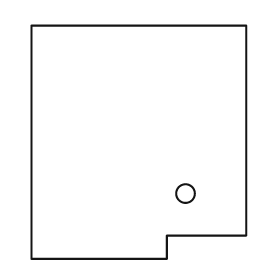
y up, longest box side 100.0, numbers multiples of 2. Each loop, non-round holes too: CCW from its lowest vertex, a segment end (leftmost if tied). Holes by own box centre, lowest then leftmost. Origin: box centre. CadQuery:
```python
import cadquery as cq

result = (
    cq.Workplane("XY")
    .moveTo(-46.0, -50.0)
    .lineTo(12.0, -50.0)
    .lineTo(12.0, -40.0)
    .lineTo(46.0, -40.0)
    .lineTo(46.0, 50.0)
    .lineTo(-46.0, 50.0)
    .close()
    .moveTo(20.0, -22.0)
    .circle(4.0)
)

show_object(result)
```